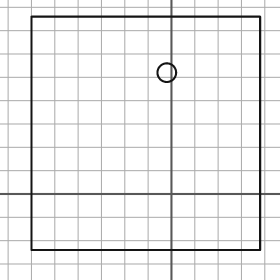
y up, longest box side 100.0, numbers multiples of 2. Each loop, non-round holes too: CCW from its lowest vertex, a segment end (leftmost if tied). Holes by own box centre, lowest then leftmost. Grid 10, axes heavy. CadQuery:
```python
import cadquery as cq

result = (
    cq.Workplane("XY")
    .moveTo(-60.0, -24.0)
    .lineTo(38.0, -24.0)
    .lineTo(38.0, 76.0)
    .lineTo(-60.0, 76.0)
    .close()
    .moveTo(-2.0, 52.0)
    .circle(4.0)
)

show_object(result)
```